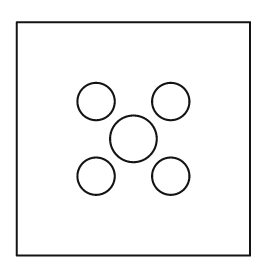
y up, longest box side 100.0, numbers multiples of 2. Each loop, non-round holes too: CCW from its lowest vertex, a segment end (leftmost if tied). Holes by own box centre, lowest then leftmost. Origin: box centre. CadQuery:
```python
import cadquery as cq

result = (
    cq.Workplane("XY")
    .moveTo(-50.0, -50.0)
    .lineTo(50.0, -50.0)
    .lineTo(50.0, 50.0)
    .lineTo(-50.0, 50.0)
    .close()
    .moveTo(-16.0, -16.0)
    .circle(8.0)
    .moveTo(16.0, -16.0)
    .circle(8.0)
    .moveTo(0.0, 0.0)
    .circle(10.0)
    .moveTo(-16.0, 16.0)
    .circle(8.0)
    .moveTo(16.0, 16.0)
    .circle(8.0)
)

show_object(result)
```